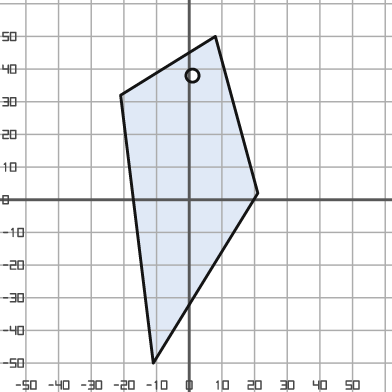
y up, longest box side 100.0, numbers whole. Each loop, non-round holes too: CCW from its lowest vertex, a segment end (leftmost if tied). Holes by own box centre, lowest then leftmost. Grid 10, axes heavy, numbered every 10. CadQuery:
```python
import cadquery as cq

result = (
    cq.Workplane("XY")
    .moveTo(-11.0, -50.0)
    .lineTo(21.0, 2.0)
    .lineTo(8.0, 50.0)
    .lineTo(-21.0, 32.0)
    .close()
    .moveTo(1.0, 38.0)
    .circle(2.0)
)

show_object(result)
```